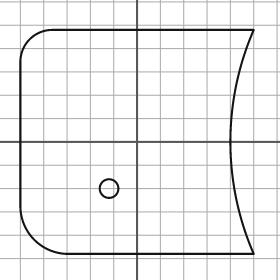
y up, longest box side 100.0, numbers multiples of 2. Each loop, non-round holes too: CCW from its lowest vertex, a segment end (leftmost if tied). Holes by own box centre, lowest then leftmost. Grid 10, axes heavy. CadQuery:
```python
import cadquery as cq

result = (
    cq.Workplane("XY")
    .moveTo(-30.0, -48.0)
    .lineTo(50.0, -48.0)
    .threePointArc((40.0, 0.0), (50.0, 48.0))
    .lineTo(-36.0, 48.0)
    .threePointArc((-46.0, 44.0), (-50.0, 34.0))
    .lineTo(-50.0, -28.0)
    .threePointArc((-44.0, -42.0), (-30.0, -48.0))
    .close()
    .moveTo(-12.0, -20.0)
    .circle(4.0)
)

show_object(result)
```